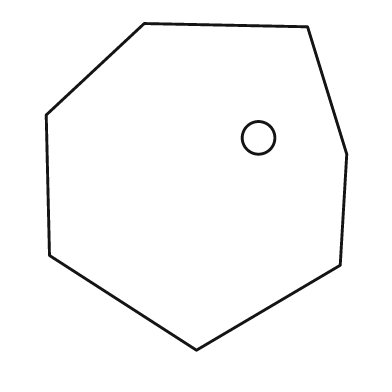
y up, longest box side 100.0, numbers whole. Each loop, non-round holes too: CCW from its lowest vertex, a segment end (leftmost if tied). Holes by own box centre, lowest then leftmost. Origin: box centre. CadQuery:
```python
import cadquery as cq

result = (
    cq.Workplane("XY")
    .moveTo(0.0, -50.0)
    .lineTo(44.0, -24.0)
    .lineTo(46.0, 10.0)
    .lineTo(34.0, 49.0)
    .lineTo(-16.0, 50.0)
    .lineTo(-46.0, 22.0)
    .lineTo(-45.0, -21.0)
    .close()
    .moveTo(19.0, 15.0)
    .circle(5.0)
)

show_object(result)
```